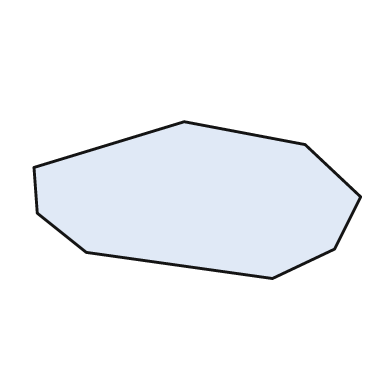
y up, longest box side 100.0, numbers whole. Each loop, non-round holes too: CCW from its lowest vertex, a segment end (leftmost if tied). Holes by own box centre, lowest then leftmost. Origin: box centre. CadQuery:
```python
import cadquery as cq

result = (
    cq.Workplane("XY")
    .moveTo(23.0, -24.0)
    .lineTo(42.0, -15.0)
    .lineTo(50.0, 1.0)
    .lineTo(33.0, 17.0)
    .lineTo(-4.0, 24.0)
    .lineTo(-50.0, 10.0)
    .lineTo(-49.0, -4.0)
    .lineTo(-34.0, -16.0)
    .close()
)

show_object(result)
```